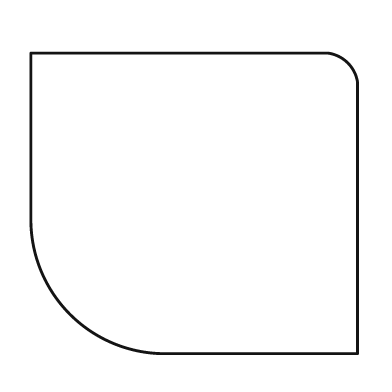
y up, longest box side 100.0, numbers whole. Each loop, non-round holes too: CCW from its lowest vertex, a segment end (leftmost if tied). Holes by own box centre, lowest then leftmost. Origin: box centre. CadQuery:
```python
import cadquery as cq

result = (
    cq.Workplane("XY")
    .moveTo(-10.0, -46.0)
    .lineTo(50.0, -46.0)
    .lineTo(50.0, 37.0)
    .threePointArc((47.0, 43.0), (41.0, 46.0))
    .lineTo(-50.0, 46.0)
    .lineTo(-50.0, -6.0)
    .threePointArc((-38.0, -34.0), (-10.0, -46.0))
    .close()
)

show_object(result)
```